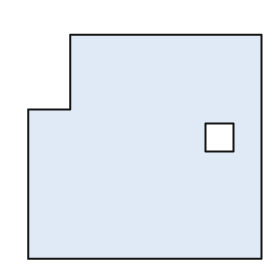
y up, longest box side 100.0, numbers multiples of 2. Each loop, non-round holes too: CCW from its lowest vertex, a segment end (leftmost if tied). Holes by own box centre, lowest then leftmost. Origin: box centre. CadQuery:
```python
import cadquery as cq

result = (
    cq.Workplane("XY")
    .moveTo(-50.0, -48.0)
    .lineTo(50.0, -48.0)
    .lineTo(50.0, 48.0)
    .lineTo(-32.0, 48.0)
    .lineTo(-32.0, 16.0)
    .lineTo(-50.0, 16.0)
    .close()
    .moveTo(26.0, -2.0)
    .lineTo(38.0, -2.0)
    .lineTo(38.0, 10.0)
    .lineTo(26.0, 10.0)
    .close()
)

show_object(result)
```